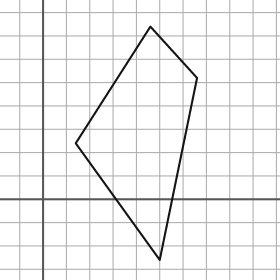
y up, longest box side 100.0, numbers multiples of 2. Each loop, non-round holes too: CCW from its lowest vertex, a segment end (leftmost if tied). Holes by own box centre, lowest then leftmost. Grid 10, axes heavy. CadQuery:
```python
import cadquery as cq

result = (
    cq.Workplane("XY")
    .moveTo(50.0, -26.0)
    .lineTo(66.0, 52.0)
    .lineTo(46.0, 74.0)
    .lineTo(14.0, 24.0)
    .close()
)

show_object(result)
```